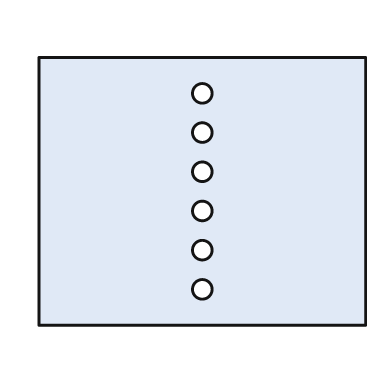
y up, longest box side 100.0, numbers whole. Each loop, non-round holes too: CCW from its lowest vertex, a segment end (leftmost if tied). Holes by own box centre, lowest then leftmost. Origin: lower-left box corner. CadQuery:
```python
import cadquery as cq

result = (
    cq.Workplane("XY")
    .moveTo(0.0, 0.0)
    .lineTo(100.0, 0.0)
    .lineTo(100.0, 82.0)
    .lineTo(0.0, 82.0)
    .close()
    .moveTo(50.0, 11.0)
    .circle(3.0)
    .moveTo(50.0, 23.0)
    .circle(3.0)
    .moveTo(50.0, 35.0)
    .circle(3.0)
    .moveTo(50.0, 47.0)
    .circle(3.0)
    .moveTo(50.0, 59.0)
    .circle(3.0)
    .moveTo(50.0, 71.0)
    .circle(3.0)
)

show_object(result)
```